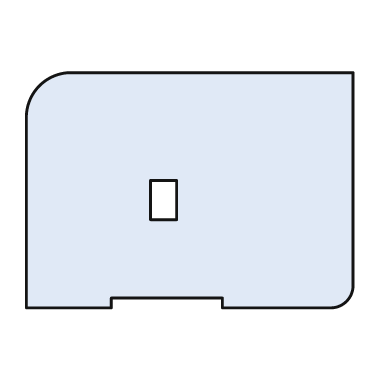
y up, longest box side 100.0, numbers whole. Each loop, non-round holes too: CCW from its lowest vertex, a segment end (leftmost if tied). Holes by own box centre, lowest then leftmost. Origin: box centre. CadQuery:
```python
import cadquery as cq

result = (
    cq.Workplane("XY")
    .moveTo(-50.0, -36.0)
    .lineTo(-24.0, -36.0)
    .lineTo(-24.0, -33.0)
    .lineTo(10.0, -33.0)
    .lineTo(10.0, -36.0)
    .lineTo(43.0, -36.0)
    .threePointArc((48.0, -34.0), (50.0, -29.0))
    .lineTo(50.0, 36.0)
    .lineTo(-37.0, 36.0)
    .threePointArc((-46.0, 32.0), (-50.0, 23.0))
    .close()
    .moveTo(-12.0, -9.0)
    .lineTo(-4.0, -9.0)
    .lineTo(-4.0, 3.0)
    .lineTo(-12.0, 3.0)
    .close()
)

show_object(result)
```